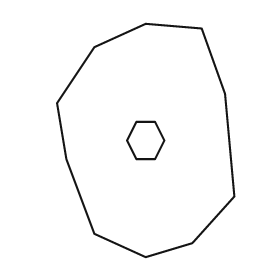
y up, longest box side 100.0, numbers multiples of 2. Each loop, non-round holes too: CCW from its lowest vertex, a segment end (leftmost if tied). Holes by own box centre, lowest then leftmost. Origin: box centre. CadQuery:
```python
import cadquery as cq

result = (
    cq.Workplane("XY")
    .moveTo(0.0, -50.0)
    .lineTo(20.0, -44.0)
    .lineTo(38.0, -24.0)
    .lineTo(34.0, 20.0)
    .lineTo(24.0, 48.0)
    .lineTo(0.0, 50.0)
    .lineTo(-22.0, 40.0)
    .lineTo(-38.0, 16.0)
    .lineTo(-34.0, -8.0)
    .lineTo(-22.0, -40.0)
    .close()
    .moveTo(-4.0, -8.0)
    .lineTo(4.0, -8.0)
    .lineTo(8.0, 0.0)
    .lineTo(4.0, 8.0)
    .lineTo(-4.0, 8.0)
    .lineTo(-8.0, 0.0)
    .close()
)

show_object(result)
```